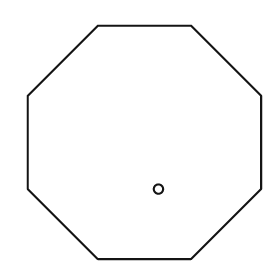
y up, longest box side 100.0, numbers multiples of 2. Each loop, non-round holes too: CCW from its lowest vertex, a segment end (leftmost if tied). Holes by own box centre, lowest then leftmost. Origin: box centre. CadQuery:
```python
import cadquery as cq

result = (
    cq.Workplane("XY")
    .moveTo(-20.0, -50.0)
    .lineTo(20.0, -50.0)
    .lineTo(50.0, -20.0)
    .lineTo(50.0, 20.0)
    .lineTo(20.0, 50.0)
    .lineTo(-20.0, 50.0)
    .lineTo(-50.0, 20.0)
    .lineTo(-50.0, -20.0)
    .close()
    .moveTo(6.0, -20.0)
    .circle(2.0)
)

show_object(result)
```